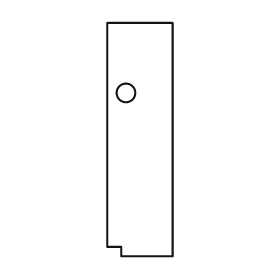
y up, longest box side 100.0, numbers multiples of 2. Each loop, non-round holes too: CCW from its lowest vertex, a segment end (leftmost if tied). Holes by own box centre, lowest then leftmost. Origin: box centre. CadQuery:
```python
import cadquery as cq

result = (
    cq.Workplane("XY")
    .moveTo(-8.0, -50.0)
    .lineTo(14.0, -50.0)
    .lineTo(14.0, 50.0)
    .lineTo(-14.0, 50.0)
    .lineTo(-14.0, -46.0)
    .lineTo(-8.0, -46.0)
    .close()
    .moveTo(-6.0, 20.0)
    .circle(4.0)
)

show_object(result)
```